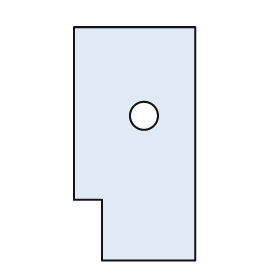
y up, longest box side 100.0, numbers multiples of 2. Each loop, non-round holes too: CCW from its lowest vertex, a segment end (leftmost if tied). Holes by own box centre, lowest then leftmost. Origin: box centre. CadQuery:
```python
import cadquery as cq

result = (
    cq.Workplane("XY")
    .moveTo(-14.0, -50.0)
    .lineTo(26.0, -50.0)
    .lineTo(26.0, 50.0)
    .lineTo(-26.0, 50.0)
    .lineTo(-26.0, -24.0)
    .lineTo(-14.0, -24.0)
    .close()
    .moveTo(4.0, 12.0)
    .circle(6.0)
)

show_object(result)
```